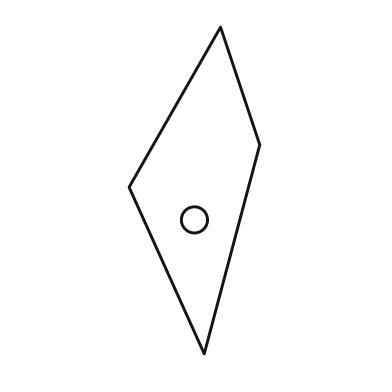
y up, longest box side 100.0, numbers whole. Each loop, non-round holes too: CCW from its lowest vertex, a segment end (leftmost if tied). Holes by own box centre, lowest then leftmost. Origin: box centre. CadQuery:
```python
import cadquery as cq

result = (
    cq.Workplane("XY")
    .moveTo(3.0, -50.0)
    .lineTo(20.0, 14.0)
    .lineTo(8.0, 50.0)
    .lineTo(-20.0, 1.0)
    .close()
    .moveTo(0.0, -9.0)
    .circle(4.0)
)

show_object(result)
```